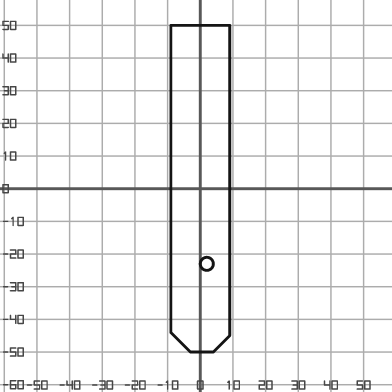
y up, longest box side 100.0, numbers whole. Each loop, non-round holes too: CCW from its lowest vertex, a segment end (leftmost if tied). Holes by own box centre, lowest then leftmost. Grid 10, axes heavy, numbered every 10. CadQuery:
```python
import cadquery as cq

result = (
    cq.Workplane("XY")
    .moveTo(-3.0, -50.0)
    .lineTo(4.0, -50.0)
    .lineTo(9.0, -45.0)
    .lineTo(9.0, 50.0)
    .lineTo(-9.0, 50.0)
    .lineTo(-9.0, -44.0)
    .close()
    .moveTo(2.0, -23.0)
    .circle(2.0)
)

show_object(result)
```